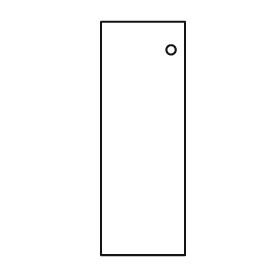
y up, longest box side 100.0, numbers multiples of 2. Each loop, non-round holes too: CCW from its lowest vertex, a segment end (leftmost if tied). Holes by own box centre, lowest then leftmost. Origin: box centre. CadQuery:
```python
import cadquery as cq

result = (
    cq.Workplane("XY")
    .moveTo(-18.0, -50.0)
    .lineTo(18.0, -50.0)
    .lineTo(18.0, 50.0)
    .lineTo(-18.0, 50.0)
    .close()
    .moveTo(12.0, 38.0)
    .circle(2.0)
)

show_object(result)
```